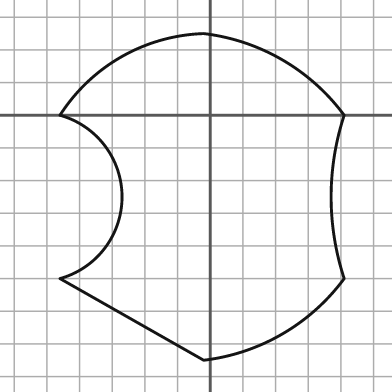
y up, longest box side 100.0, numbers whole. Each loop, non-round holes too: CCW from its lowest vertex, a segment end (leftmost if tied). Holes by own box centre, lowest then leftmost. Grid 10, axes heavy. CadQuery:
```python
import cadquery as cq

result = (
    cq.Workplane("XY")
    .moveTo(-2.0, -75.0)
    .threePointArc((22.0, -67.0), (41.0, -50.0))
    .threePointArc((37.0, -25.0), (41.0, 0.0))
    .threePointArc((22.0, 17.0), (-2.0, 25.0))
    .threePointArc((-27.0, 18.0), (-46.0, 0.0))
    .threePointArc((-27.0, -25.0), (-46.0, -50.0))
    .close()
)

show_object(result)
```